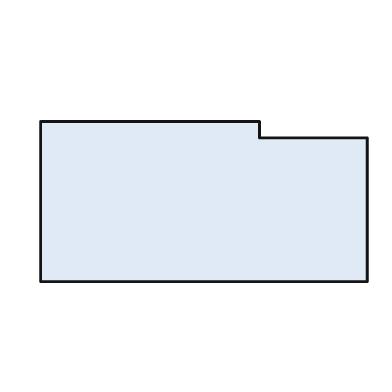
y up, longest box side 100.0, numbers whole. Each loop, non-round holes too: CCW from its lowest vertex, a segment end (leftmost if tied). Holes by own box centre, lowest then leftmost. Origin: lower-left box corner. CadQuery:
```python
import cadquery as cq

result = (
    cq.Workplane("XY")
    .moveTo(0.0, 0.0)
    .lineTo(100.0, 0.0)
    .lineTo(100.0, 44.0)
    .lineTo(67.0, 44.0)
    .lineTo(67.0, 49.0)
    .lineTo(0.0, 49.0)
    .close()
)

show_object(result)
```